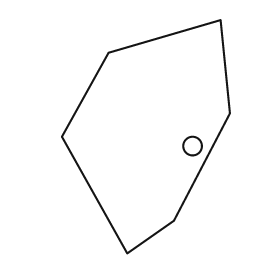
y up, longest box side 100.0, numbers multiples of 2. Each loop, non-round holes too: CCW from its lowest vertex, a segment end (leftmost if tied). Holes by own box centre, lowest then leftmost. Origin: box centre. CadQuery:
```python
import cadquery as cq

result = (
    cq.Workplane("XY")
    .moveTo(-8.0, -50.0)
    .lineTo(12.0, -36.0)
    .lineTo(36.0, 10.0)
    .lineTo(32.0, 50.0)
    .lineTo(-16.0, 36.0)
    .lineTo(-36.0, 0.0)
    .close()
    .moveTo(20.0, -4.0)
    .circle(4.0)
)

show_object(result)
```